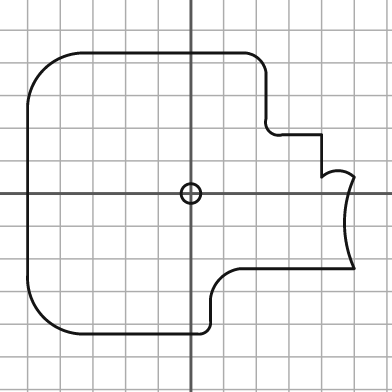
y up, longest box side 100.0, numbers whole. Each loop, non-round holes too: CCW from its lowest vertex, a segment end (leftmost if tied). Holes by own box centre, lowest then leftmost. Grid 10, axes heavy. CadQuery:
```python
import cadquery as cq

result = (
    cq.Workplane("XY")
    .moveTo(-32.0, -43.0)
    .lineTo(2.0, -43.0)
    .threePointArc((5.0, -42.0), (6.0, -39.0))
    .lineTo(6.0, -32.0)
    .threePointArc((9.0, -26.0), (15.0, -23.0))
    .lineTo(50.0, -23.0)
    .threePointArc((47.0, -9.0), (50.0, 5.0))
    .threePointArc((45.0, 7.0), (40.0, 5.0))
    .lineTo(40.0, 18.0)
    .lineTo(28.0, 18.0)
    .threePointArc((24.0, 19.0), (23.0, 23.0))
    .lineTo(23.0, 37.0)
    .threePointArc((21.0, 41.0), (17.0, 43.0))
    .lineTo(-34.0, 43.0)
    .threePointArc((-45.0, 38.0), (-50.0, 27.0))
    .lineTo(-50.0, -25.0)
    .threePointArc((-45.0, -38.0), (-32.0, -43.0))
    .close()
    .moveTo(0.0, 0.0)
    .circle(3.0)
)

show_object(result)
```